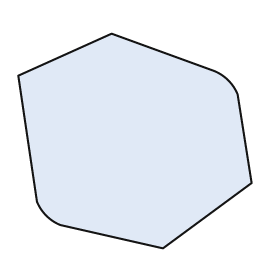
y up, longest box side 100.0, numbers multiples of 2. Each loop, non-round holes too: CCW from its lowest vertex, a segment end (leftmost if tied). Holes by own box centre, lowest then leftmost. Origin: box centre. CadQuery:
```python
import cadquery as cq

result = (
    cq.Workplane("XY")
    .moveTo(12.0, -46.0)
    .lineTo(50.0, -18.0)
    .lineTo(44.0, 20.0)
    .threePointArc((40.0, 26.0), (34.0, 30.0))
    .lineTo(-10.0, 46.0)
    .lineTo(-50.0, 28.0)
    .lineTo(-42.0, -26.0)
    .threePointArc((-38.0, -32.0), (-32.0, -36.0))
    .close()
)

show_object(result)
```